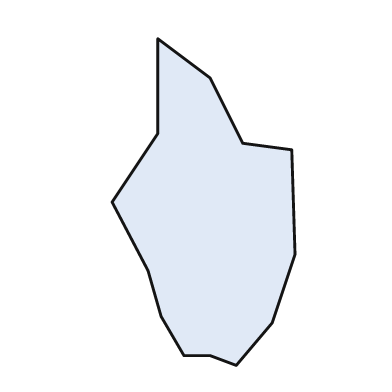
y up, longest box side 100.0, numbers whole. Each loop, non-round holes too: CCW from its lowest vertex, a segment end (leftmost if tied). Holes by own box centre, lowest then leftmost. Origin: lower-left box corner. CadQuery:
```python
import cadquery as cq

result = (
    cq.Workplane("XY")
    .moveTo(38.0, 0.0)
    .lineTo(49.0, 13.0)
    .lineTo(56.0, 34.0)
    .lineTo(55.0, 66.0)
    .lineTo(40.0, 68.0)
    .lineTo(30.0, 88.0)
    .lineTo(14.0, 100.0)
    .lineTo(14.0, 71.0)
    .lineTo(0.0, 50.0)
    .lineTo(11.0, 29.0)
    .lineTo(15.0, 15.0)
    .lineTo(22.0, 3.0)
    .lineTo(30.0, 3.0)
    .close()
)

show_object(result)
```